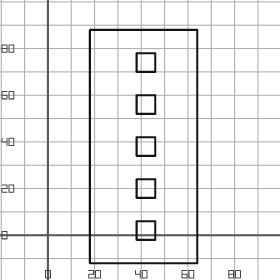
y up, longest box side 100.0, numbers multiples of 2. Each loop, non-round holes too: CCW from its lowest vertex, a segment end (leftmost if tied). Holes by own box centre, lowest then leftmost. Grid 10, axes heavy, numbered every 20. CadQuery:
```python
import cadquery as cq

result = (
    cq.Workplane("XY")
    .moveTo(18.0, -12.0)
    .lineTo(64.0, -12.0)
    .lineTo(64.0, 88.0)
    .lineTo(18.0, 88.0)
    .close()
    .moveTo(38.0, -2.0)
    .lineTo(46.0, -2.0)
    .lineTo(46.0, 6.0)
    .lineTo(38.0, 6.0)
    .close()
    .moveTo(38.0, 16.0)
    .lineTo(46.0, 16.0)
    .lineTo(46.0, 24.0)
    .lineTo(38.0, 24.0)
    .close()
    .moveTo(38.0, 34.0)
    .lineTo(46.0, 34.0)
    .lineTo(46.0, 42.0)
    .lineTo(38.0, 42.0)
    .close()
    .moveTo(38.0, 52.0)
    .lineTo(46.0, 52.0)
    .lineTo(46.0, 60.0)
    .lineTo(38.0, 60.0)
    .close()
    .moveTo(38.0, 70.0)
    .lineTo(46.0, 70.0)
    .lineTo(46.0, 78.0)
    .lineTo(38.0, 78.0)
    .close()
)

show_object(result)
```